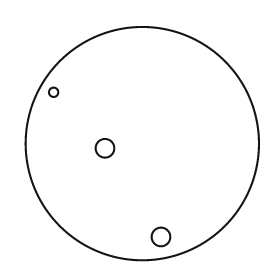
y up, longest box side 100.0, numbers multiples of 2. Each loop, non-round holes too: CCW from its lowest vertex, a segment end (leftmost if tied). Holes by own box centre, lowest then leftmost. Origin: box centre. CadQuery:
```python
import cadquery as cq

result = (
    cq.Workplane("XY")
    .moveTo(0.0, 0.0)
    .circle(50.0)
    .moveTo(8.0, -40.0)
    .circle(4.0)
    .moveTo(-16.0, -2.0)
    .circle(4.0)
    .moveTo(-38.0, 22.0)
    .circle(2.0)
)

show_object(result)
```